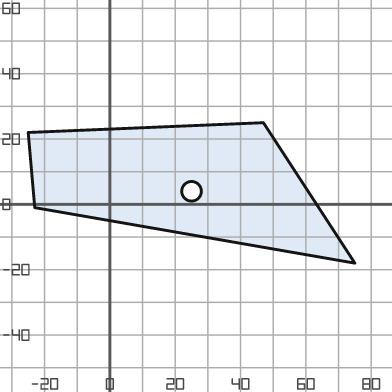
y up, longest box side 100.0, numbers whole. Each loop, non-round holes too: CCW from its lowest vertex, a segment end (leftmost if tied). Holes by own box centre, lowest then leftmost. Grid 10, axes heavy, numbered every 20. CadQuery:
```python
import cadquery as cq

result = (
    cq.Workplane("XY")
    .moveTo(75.0, -18.0)
    .lineTo(47.0, 25.0)
    .lineTo(-25.0, 22.0)
    .lineTo(-23.0, -1.0)
    .close()
    .moveTo(25.0, 4.0)
    .circle(3.0)
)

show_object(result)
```